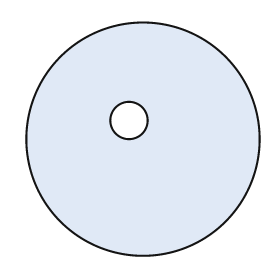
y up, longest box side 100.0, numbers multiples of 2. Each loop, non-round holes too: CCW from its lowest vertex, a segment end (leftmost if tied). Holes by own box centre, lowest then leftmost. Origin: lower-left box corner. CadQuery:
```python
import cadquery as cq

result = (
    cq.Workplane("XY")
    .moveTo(50.0, 50.0)
    .circle(50.0)
    .moveTo(44.0, 58.0)
    .circle(8.0)
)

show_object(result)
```